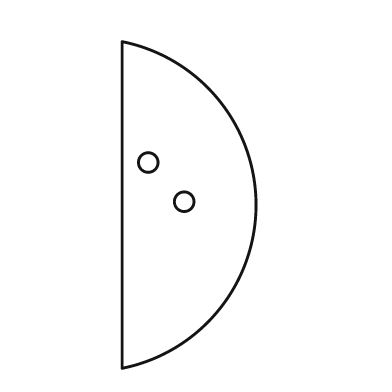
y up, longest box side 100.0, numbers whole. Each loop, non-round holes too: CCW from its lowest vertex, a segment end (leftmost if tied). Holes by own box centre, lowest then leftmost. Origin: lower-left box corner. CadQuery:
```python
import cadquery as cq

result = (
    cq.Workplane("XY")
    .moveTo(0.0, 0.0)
    .threePointArc((41.0, 50.0), (0.0, 100.0))
    .close()
    .moveTo(19.0, 51.0)
    .circle(3.0)
    .moveTo(8.0, 63.0)
    .circle(3.0)
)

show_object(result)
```